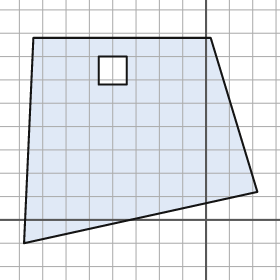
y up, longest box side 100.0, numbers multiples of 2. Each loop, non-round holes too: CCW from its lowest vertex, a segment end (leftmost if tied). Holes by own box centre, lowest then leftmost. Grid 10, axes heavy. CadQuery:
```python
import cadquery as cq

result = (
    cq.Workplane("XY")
    .moveTo(-78.0, -10.0)
    .lineTo(22.0, 12.0)
    .lineTo(2.0, 78.0)
    .lineTo(-74.0, 78.0)
    .close()
    .moveTo(-46.0, 58.0)
    .lineTo(-34.0, 58.0)
    .lineTo(-34.0, 70.0)
    .lineTo(-46.0, 70.0)
    .close()
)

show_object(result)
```